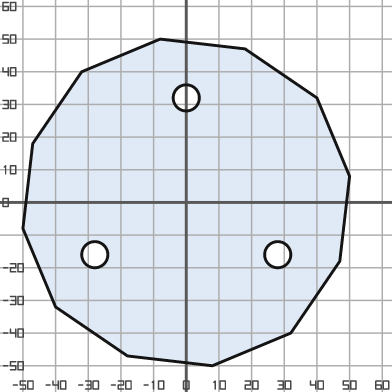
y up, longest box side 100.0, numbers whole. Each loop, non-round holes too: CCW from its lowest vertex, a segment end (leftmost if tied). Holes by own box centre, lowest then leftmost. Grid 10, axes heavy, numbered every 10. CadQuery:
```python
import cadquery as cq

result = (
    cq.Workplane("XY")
    .moveTo(8.0, -50.0)
    .lineTo(32.0, -40.0)
    .lineTo(47.0, -18.0)
    .lineTo(50.0, 8.0)
    .lineTo(40.0, 32.0)
    .lineTo(18.0, 47.0)
    .lineTo(-8.0, 50.0)
    .lineTo(-32.0, 40.0)
    .lineTo(-47.0, 18.0)
    .lineTo(-50.0, -8.0)
    .lineTo(-40.0, -32.0)
    .lineTo(-18.0, -47.0)
    .close()
    .moveTo(-28.0, -16.0)
    .circle(4.0)
    .moveTo(28.0, -16.0)
    .circle(4.0)
    .moveTo(0.0, 32.0)
    .circle(4.0)
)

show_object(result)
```